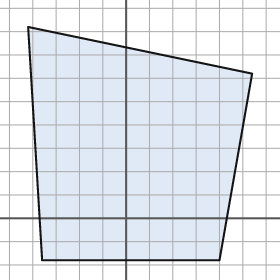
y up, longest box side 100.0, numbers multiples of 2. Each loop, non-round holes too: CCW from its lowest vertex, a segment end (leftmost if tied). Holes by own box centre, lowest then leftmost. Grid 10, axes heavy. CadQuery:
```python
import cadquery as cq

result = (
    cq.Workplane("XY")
    .moveTo(-36.0, -18.0)
    .lineTo(40.0, -18.0)
    .lineTo(54.0, 62.0)
    .lineTo(-42.0, 82.0)
    .close()
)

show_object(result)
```